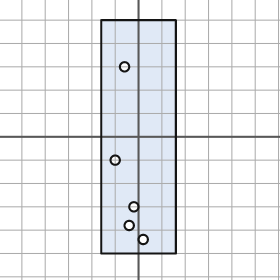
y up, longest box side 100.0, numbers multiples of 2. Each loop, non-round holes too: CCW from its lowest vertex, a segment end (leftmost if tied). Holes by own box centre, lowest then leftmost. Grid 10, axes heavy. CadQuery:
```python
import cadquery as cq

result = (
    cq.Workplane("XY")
    .moveTo(-16.0, -50.0)
    .lineTo(16.0, -50.0)
    .lineTo(16.0, 50.0)
    .lineTo(-16.0, 50.0)
    .close()
    .moveTo(2.0, -44.0)
    .circle(2.0)
    .moveTo(-4.0, -38.0)
    .circle(2.0)
    .moveTo(-2.0, -30.0)
    .circle(2.0)
    .moveTo(-10.0, -10.0)
    .circle(2.0)
    .moveTo(-6.0, 30.0)
    .circle(2.0)
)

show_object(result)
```